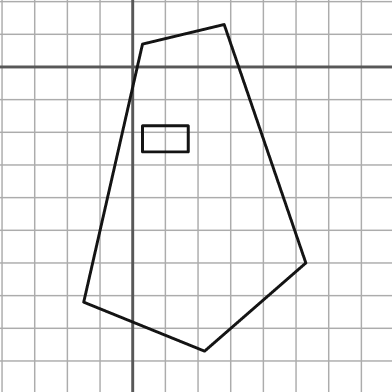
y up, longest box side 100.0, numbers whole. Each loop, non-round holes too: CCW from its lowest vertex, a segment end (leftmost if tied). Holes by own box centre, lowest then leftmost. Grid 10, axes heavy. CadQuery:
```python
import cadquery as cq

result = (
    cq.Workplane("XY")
    .moveTo(22.0, -87.0)
    .lineTo(53.0, -60.0)
    .lineTo(28.0, 13.0)
    .lineTo(3.0, 7.0)
    .lineTo(-15.0, -72.0)
    .close()
    .moveTo(3.0, -26.0)
    .lineTo(17.0, -26.0)
    .lineTo(17.0, -18.0)
    .lineTo(3.0, -18.0)
    .close()
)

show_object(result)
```